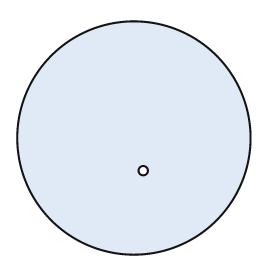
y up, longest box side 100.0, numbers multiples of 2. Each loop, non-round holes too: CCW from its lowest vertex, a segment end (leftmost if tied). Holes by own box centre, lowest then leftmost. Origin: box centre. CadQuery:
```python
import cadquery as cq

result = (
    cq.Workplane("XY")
    .moveTo(0.0, 0.0)
    .circle(50.0)
    .moveTo(4.0, -14.0)
    .circle(2.0)
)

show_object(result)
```